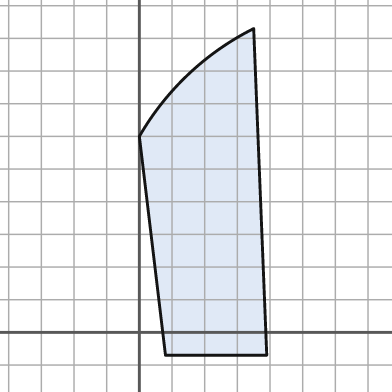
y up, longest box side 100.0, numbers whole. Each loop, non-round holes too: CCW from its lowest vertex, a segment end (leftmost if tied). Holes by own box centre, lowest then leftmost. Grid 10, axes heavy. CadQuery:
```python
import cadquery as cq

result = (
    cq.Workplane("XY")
    .moveTo(8.0, -7.0)
    .lineTo(39.0, -7.0)
    .lineTo(35.0, 93.0)
    .threePointArc((15.0, 79.0), (0.0, 60.0))
    .close()
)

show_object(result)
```